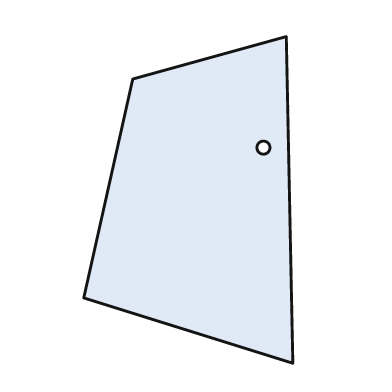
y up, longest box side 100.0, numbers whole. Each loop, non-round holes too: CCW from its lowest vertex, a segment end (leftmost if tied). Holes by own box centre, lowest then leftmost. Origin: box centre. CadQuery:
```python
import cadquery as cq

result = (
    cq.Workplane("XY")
    .moveTo(32.0, -50.0)
    .lineTo(30.0, 50.0)
    .lineTo(-17.0, 37.0)
    .lineTo(-32.0, -30.0)
    .close()
    .moveTo(23.0, 16.0)
    .circle(2.0)
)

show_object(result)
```